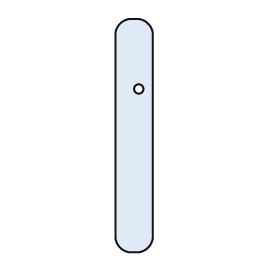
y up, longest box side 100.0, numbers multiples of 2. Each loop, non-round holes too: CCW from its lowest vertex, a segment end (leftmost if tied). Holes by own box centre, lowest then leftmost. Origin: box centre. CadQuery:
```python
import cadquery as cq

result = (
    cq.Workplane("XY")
    .moveTo(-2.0, -50.0)
    .lineTo(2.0, -50.0)
    .threePointArc((6.0, -48.0), (8.0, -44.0))
    .lineTo(8.0, 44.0)
    .threePointArc((6.0, 48.0), (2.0, 50.0))
    .lineTo(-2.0, 50.0)
    .threePointArc((-6.0, 48.0), (-8.0, 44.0))
    .lineTo(-8.0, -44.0)
    .threePointArc((-6.0, -48.0), (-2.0, -50.0))
    .close()
    .moveTo(2.0, 20.0)
    .circle(2.0)
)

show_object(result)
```